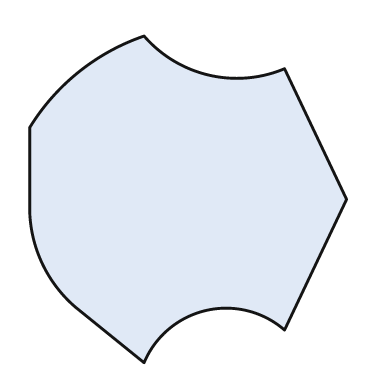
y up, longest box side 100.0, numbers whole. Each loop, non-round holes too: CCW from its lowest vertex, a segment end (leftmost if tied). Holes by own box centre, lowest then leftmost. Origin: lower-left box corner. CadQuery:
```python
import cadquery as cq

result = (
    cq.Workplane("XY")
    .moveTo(35.0, 0.0)
    .threePointArc((54.0, 16.0), (78.0, 10.0))
    .lineTo(97.0, 50.0)
    .lineTo(78.0, 90.0)
    .threePointArc((55.0, 88.0), (35.0, 100.0))
    .threePointArc((15.0, 89.0), (0.0, 72.0))
    .lineTo(0.0, 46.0)
    .threePointArc((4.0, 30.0), (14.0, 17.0))
    .close()
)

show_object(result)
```